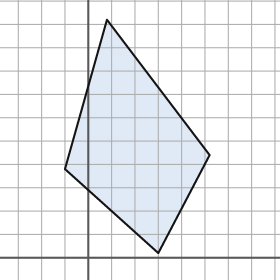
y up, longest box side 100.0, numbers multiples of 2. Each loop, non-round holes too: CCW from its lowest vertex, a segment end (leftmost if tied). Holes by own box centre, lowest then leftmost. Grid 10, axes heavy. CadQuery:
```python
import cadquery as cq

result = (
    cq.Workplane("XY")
    .moveTo(30.0, 2.0)
    .lineTo(52.0, 44.0)
    .lineTo(8.0, 102.0)
    .lineTo(-10.0, 38.0)
    .close()
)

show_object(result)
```